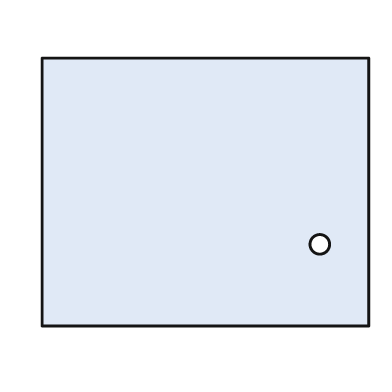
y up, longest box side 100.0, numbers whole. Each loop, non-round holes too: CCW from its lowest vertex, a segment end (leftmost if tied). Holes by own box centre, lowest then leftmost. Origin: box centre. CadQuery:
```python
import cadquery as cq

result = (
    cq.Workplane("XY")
    .moveTo(-50.0, -41.0)
    .lineTo(50.0, -41.0)
    .lineTo(50.0, 41.0)
    .lineTo(-50.0, 41.0)
    .close()
    .moveTo(35.0, -16.0)
    .circle(3.0)
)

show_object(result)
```